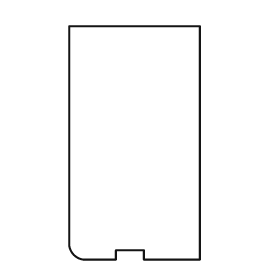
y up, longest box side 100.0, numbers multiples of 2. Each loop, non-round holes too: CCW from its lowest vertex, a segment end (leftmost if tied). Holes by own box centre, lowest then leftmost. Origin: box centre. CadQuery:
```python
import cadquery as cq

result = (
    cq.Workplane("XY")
    .moveTo(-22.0, -50.0)
    .lineTo(-8.0, -50.0)
    .lineTo(-8.0, -46.0)
    .lineTo(4.0, -46.0)
    .lineTo(4.0, -50.0)
    .lineTo(28.0, -50.0)
    .lineTo(28.0, 50.0)
    .lineTo(-28.0, 50.0)
    .lineTo(-28.0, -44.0)
    .threePointArc((-26.0, -48.0), (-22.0, -50.0))
    .close()
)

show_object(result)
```